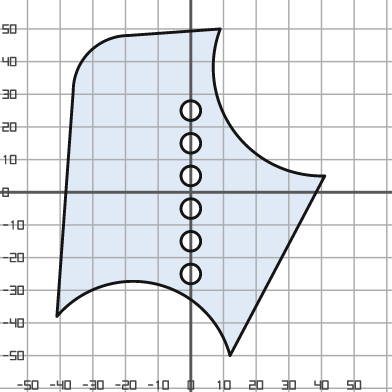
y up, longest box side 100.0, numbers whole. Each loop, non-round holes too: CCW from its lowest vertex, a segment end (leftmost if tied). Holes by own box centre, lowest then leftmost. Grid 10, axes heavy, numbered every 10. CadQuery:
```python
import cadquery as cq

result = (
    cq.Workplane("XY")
    .moveTo(12.0, -50.0)
    .lineTo(41.0, 5.0)
    .threePointArc((13.0, 19.0), (9.0, 50.0))
    .lineTo(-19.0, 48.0)
    .threePointArc((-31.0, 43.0), (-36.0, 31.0))
    .lineTo(-41.0, -38.0)
    .threePointArc((-11.0, -28.0), (12.0, -50.0))
    .close()
    .moveTo(0.0, -25.0)
    .circle(3.0)
    .moveTo(0.0, -15.0)
    .circle(3.0)
    .moveTo(0.0, -5.0)
    .circle(3.0)
    .moveTo(0.0, 5.0)
    .circle(3.0)
    .moveTo(0.0, 15.0)
    .circle(3.0)
    .moveTo(0.0, 25.0)
    .circle(3.0)
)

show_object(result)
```